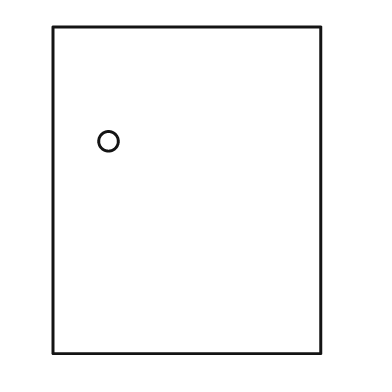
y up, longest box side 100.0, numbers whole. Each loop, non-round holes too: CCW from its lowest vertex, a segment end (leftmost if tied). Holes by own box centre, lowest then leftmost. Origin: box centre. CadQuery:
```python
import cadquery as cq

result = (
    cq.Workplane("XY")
    .moveTo(-41.0, -50.0)
    .lineTo(41.0, -50.0)
    .lineTo(41.0, 50.0)
    .lineTo(-41.0, 50.0)
    .close()
    .moveTo(-24.0, 15.0)
    .circle(3.0)
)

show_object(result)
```